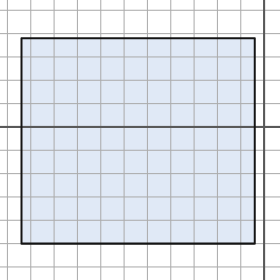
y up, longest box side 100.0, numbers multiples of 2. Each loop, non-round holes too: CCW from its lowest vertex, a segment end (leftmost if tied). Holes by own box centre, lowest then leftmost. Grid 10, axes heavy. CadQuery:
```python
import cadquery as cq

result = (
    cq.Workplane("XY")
    .moveTo(-104.0, -50.0)
    .lineTo(-4.0, -50.0)
    .lineTo(-4.0, 38.0)
    .lineTo(-104.0, 38.0)
    .close()
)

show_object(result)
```